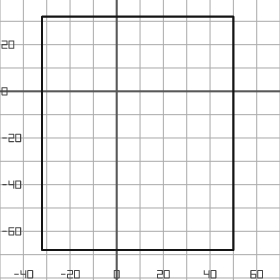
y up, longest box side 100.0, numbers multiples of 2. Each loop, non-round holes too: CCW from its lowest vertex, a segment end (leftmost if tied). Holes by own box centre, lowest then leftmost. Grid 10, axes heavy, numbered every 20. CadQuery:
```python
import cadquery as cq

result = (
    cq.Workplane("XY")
    .moveTo(-32.0, -68.0)
    .lineTo(50.0, -68.0)
    .lineTo(50.0, 32.0)
    .lineTo(-32.0, 32.0)
    .close()
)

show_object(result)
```